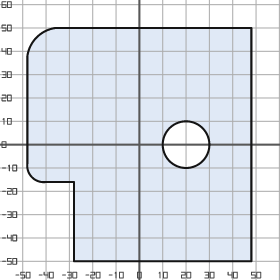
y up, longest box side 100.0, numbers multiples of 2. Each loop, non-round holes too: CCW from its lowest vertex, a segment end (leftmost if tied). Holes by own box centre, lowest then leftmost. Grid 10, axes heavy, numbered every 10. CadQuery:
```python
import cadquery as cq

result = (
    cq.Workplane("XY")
    .moveTo(-28.0, -50.0)
    .lineTo(48.0, -50.0)
    .lineTo(48.0, 50.0)
    .lineTo(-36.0, 50.0)
    .threePointArc((-44.0, 46.0), (-48.0, 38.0))
    .lineTo(-48.0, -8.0)
    .threePointArc((-46.0, -14.0), (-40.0, -16.0))
    .lineTo(-28.0, -16.0)
    .close()
    .moveTo(20.0, 0.0)
    .circle(10.0)
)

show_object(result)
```